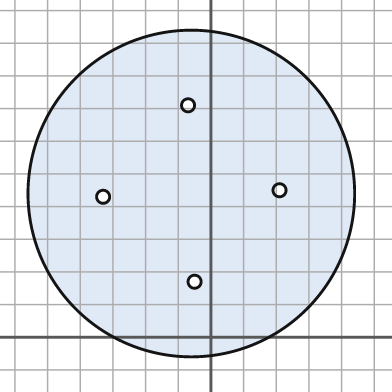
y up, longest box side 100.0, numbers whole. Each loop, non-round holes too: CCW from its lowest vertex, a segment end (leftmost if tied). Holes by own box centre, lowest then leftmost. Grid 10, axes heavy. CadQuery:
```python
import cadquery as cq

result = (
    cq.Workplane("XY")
    .moveTo(-6.0, 44.0)
    .circle(50.0)
    .moveTo(-5.0, 17.0)
    .circle(2.0)
    .moveTo(-33.0, 43.0)
    .circle(2.0)
    .moveTo(21.0, 45.0)
    .circle(2.0)
    .moveTo(-7.0, 71.0)
    .circle(2.0)
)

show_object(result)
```